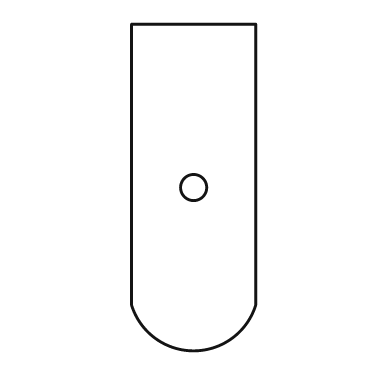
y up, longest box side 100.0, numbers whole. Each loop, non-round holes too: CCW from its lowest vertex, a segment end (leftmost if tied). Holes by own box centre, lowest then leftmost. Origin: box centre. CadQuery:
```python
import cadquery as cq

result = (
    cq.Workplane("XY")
    .moveTo(-19.0, -36.0)
    .threePointArc((0.0, -50.0), (19.0, -36.0))
    .lineTo(19.0, 50.0)
    .lineTo(-19.0, 50.0)
    .close()
    .moveTo(0.0, 0.0)
    .circle(4.0)
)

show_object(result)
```